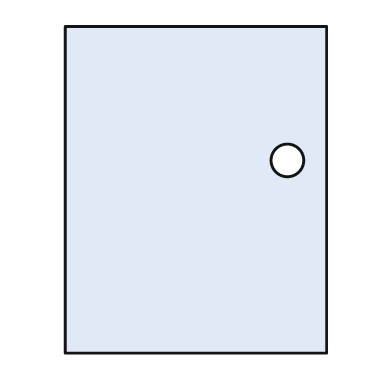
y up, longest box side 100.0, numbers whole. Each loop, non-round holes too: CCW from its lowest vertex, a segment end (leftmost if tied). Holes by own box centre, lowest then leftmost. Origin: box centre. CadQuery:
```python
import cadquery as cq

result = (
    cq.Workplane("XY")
    .moveTo(-40.0, -50.0)
    .lineTo(40.0, -50.0)
    .lineTo(40.0, 50.0)
    .lineTo(-40.0, 50.0)
    .close()
    .moveTo(28.0, 9.0)
    .circle(5.0)
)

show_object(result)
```